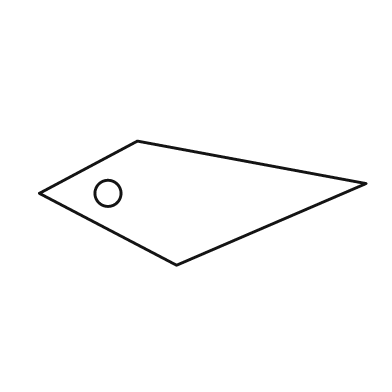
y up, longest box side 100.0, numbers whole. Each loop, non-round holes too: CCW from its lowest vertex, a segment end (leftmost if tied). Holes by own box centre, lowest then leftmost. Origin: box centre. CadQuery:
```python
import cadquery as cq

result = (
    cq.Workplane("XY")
    .moveTo(-8.0, -19.0)
    .lineTo(50.0, 6.0)
    .lineTo(-20.0, 19.0)
    .lineTo(-50.0, 3.0)
    .close()
    .moveTo(-29.0, 3.0)
    .circle(4.0)
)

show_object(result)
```